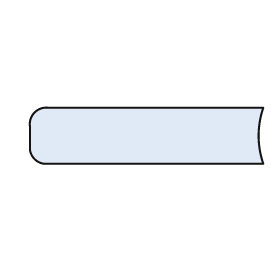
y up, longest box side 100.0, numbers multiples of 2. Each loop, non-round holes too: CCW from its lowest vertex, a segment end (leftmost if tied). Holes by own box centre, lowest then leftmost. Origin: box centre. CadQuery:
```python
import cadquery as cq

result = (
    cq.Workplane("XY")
    .moveTo(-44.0, -12.0)
    .lineTo(50.0, -12.0)
    .threePointArc((48.0, 0.0), (50.0, 12.0))
    .lineTo(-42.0, 12.0)
    .threePointArc((-48.0, 10.0), (-50.0, 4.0))
    .lineTo(-50.0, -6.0)
    .threePointArc((-48.0, -10.0), (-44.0, -12.0))
    .close()
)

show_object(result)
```